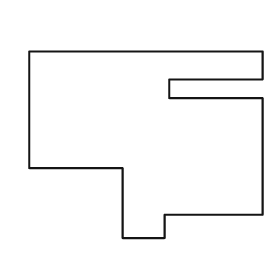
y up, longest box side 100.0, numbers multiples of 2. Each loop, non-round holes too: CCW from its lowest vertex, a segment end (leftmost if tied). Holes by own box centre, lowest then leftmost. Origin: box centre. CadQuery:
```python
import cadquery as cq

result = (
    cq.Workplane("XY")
    .moveTo(-10.0, -40.0)
    .lineTo(8.0, -40.0)
    .lineTo(8.0, -30.0)
    .lineTo(50.0, -30.0)
    .lineTo(50.0, 20.0)
    .lineTo(10.0, 20.0)
    .lineTo(10.0, 28.0)
    .lineTo(50.0, 28.0)
    .lineTo(50.0, 40.0)
    .lineTo(-50.0, 40.0)
    .lineTo(-50.0, -10.0)
    .lineTo(-10.0, -10.0)
    .close()
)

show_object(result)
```